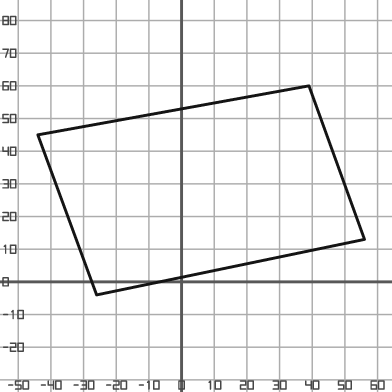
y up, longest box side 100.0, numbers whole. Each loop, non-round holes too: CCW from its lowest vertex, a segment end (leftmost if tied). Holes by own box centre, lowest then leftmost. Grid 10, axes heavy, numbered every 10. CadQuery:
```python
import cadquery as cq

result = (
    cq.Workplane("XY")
    .moveTo(-26.0, -4.0)
    .lineTo(56.0, 13.0)
    .lineTo(39.0, 60.0)
    .lineTo(-44.0, 45.0)
    .close()
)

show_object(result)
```